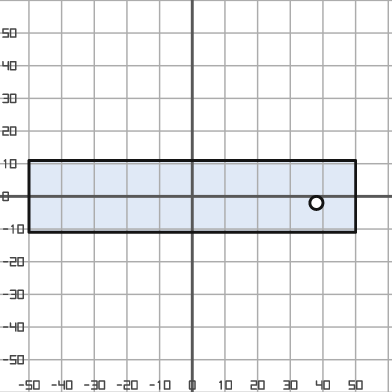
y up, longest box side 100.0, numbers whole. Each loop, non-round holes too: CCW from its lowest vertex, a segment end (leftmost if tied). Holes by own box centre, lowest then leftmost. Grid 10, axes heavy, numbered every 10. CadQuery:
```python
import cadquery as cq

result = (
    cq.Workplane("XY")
    .moveTo(-50.0, -11.0)
    .lineTo(50.0, -11.0)
    .lineTo(50.0, 11.0)
    .lineTo(-50.0, 11.0)
    .close()
    .moveTo(38.0, -2.0)
    .circle(2.0)
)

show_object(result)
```